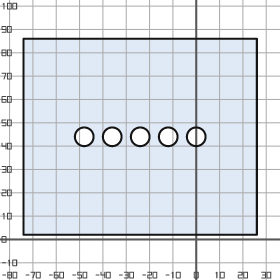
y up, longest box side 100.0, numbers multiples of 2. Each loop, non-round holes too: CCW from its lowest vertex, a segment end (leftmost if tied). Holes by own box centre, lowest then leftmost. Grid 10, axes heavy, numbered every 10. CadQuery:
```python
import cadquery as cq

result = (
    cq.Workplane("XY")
    .moveTo(-74.0, 2.0)
    .lineTo(26.0, 2.0)
    .lineTo(26.0, 86.0)
    .lineTo(-74.0, 86.0)
    .close()
    .moveTo(-48.0, 44.0)
    .circle(4.0)
    .moveTo(-36.0, 44.0)
    .circle(4.0)
    .moveTo(-24.0, 44.0)
    .circle(4.0)
    .moveTo(-12.0, 44.0)
    .circle(4.0)
    .moveTo(0.0, 44.0)
    .circle(4.0)
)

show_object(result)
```